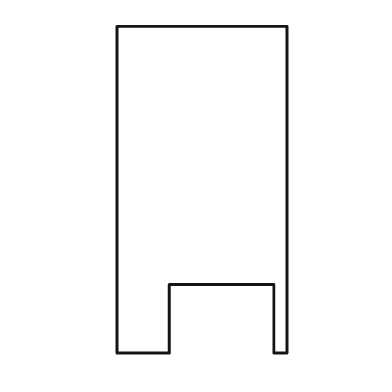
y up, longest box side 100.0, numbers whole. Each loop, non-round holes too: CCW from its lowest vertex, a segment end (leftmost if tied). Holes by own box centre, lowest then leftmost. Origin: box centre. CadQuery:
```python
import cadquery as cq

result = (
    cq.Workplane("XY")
    .moveTo(-26.0, -50.0)
    .lineTo(-10.0, -50.0)
    .lineTo(-10.0, -29.0)
    .lineTo(22.0, -29.0)
    .lineTo(22.0, -50.0)
    .lineTo(26.0, -50.0)
    .lineTo(26.0, 50.0)
    .lineTo(-26.0, 50.0)
    .close()
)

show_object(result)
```